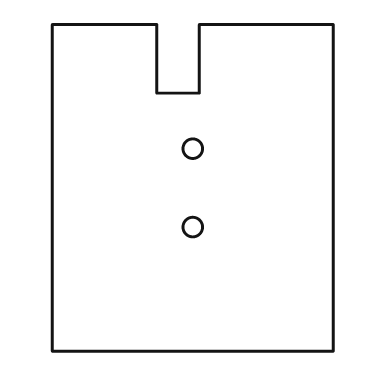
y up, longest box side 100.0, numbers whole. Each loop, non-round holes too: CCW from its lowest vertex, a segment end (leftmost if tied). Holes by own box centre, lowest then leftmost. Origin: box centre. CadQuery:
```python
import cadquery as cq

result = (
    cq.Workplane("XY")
    .moveTo(-43.0, -50.0)
    .lineTo(43.0, -50.0)
    .lineTo(43.0, 50.0)
    .lineTo(2.0, 50.0)
    .lineTo(2.0, 29.0)
    .lineTo(-11.0, 29.0)
    .lineTo(-11.0, 50.0)
    .lineTo(-43.0, 50.0)
    .close()
    .moveTo(0.0, -12.0)
    .circle(3.0)
    .moveTo(0.0, 12.0)
    .circle(3.0)
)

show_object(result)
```